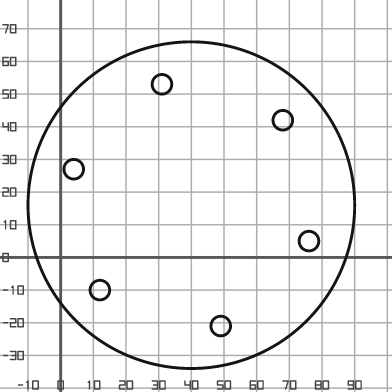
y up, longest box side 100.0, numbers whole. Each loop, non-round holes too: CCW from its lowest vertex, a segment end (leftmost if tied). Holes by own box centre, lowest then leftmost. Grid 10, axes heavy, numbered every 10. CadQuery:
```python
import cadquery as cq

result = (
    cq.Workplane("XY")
    .moveTo(40.0, 16.0)
    .circle(50.0)
    .moveTo(49.0, -21.0)
    .circle(3.0)
    .moveTo(12.0, -10.0)
    .circle(3.0)
    .moveTo(76.0, 5.0)
    .circle(3.0)
    .moveTo(4.0, 27.0)
    .circle(3.0)
    .moveTo(68.0, 42.0)
    .circle(3.0)
    .moveTo(31.0, 53.0)
    .circle(3.0)
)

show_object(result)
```